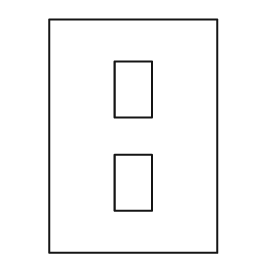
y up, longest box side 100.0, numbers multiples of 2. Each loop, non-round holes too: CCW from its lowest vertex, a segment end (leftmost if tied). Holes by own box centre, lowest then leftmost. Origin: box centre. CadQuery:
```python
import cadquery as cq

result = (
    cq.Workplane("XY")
    .moveTo(-36.0, -50.0)
    .lineTo(36.0, -50.0)
    .lineTo(36.0, 50.0)
    .lineTo(-36.0, 50.0)
    .close()
    .moveTo(-8.0, -32.0)
    .lineTo(8.0, -32.0)
    .lineTo(8.0, -8.0)
    .lineTo(-8.0, -8.0)
    .close()
    .moveTo(-8.0, 8.0)
    .lineTo(8.0, 8.0)
    .lineTo(8.0, 32.0)
    .lineTo(-8.0, 32.0)
    .close()
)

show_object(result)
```